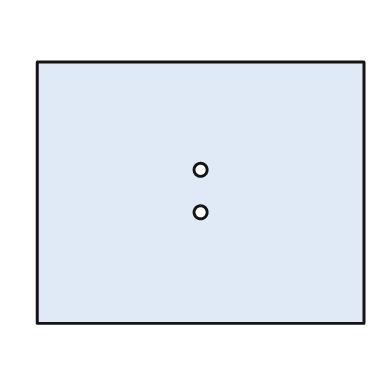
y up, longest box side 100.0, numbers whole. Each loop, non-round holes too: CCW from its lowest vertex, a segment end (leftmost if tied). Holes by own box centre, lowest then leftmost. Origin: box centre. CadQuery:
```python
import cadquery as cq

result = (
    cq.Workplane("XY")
    .moveTo(-50.0, -40.0)
    .lineTo(50.0, -40.0)
    .lineTo(50.0, 40.0)
    .lineTo(-50.0, 40.0)
    .close()
    .moveTo(0.0, -6.0)
    .circle(2.0)
    .moveTo(0.0, 7.0)
    .circle(2.0)
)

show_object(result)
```